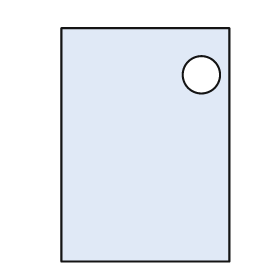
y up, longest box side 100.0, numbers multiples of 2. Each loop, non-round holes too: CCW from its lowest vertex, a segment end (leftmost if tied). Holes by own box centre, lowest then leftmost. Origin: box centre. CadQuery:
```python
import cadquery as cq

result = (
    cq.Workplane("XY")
    .moveTo(-36.0, -50.0)
    .lineTo(36.0, -50.0)
    .lineTo(36.0, 50.0)
    .lineTo(-36.0, 50.0)
    .close()
    .moveTo(24.0, 30.0)
    .circle(8.0)
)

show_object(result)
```